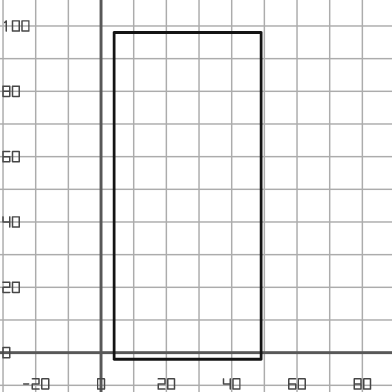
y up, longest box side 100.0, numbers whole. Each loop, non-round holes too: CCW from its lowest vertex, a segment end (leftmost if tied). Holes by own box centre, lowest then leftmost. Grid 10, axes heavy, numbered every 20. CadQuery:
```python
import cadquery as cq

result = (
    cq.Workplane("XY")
    .moveTo(4.0, -2.0)
    .lineTo(49.0, -2.0)
    .lineTo(49.0, 98.0)
    .lineTo(4.0, 98.0)
    .close()
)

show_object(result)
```